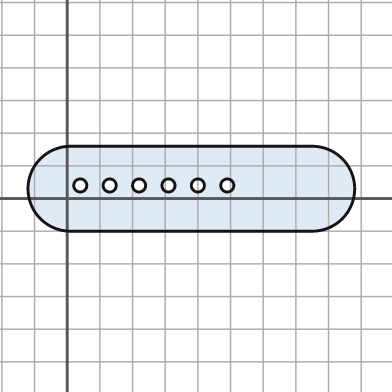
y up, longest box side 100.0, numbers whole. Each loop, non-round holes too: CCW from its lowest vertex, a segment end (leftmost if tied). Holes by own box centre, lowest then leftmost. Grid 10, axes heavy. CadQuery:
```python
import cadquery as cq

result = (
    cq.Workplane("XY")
    .moveTo(1.0, -10.0)
    .lineTo(75.0, -10.0)
    .threePointArc((88.0, 3.0), (75.0, 16.0))
    .lineTo(1.0, 16.0)
    .threePointArc((-12.0, 3.0), (1.0, -10.0))
    .close()
    .moveTo(4.0, 4.0)
    .circle(2.0)
    .moveTo(13.0, 4.0)
    .circle(2.0)
    .moveTo(22.0, 4.0)
    .circle(2.0)
    .moveTo(31.0, 4.0)
    .circle(2.0)
    .moveTo(40.0, 4.0)
    .circle(2.0)
    .moveTo(49.0, 4.0)
    .circle(2.0)
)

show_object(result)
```